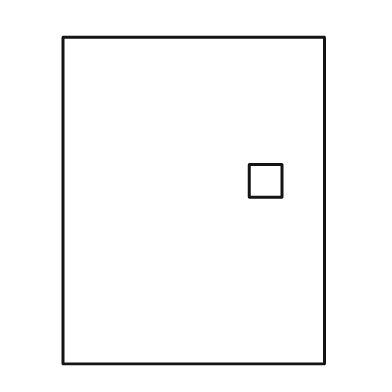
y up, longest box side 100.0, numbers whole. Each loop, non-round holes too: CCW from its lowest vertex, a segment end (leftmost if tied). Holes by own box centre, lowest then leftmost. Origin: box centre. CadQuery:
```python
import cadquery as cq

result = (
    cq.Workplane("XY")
    .moveTo(-40.0, -50.0)
    .lineTo(40.0, -50.0)
    .lineTo(40.0, 50.0)
    .lineTo(-40.0, 50.0)
    .close()
    .moveTo(17.0, 1.0)
    .lineTo(27.0, 1.0)
    .lineTo(27.0, 11.0)
    .lineTo(17.0, 11.0)
    .close()
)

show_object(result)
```